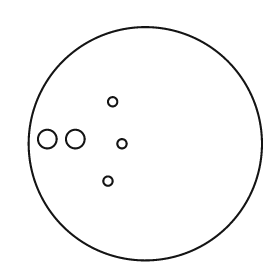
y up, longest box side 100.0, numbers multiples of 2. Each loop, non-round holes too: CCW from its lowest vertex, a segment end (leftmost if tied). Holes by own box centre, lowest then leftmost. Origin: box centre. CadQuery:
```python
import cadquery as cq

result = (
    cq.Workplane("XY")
    .moveTo(0.0, 0.0)
    .circle(50.0)
    .moveTo(-16.0, -16.0)
    .circle(2.0)
    .moveTo(-10.0, 0.0)
    .circle(2.0)
    .moveTo(-42.0, 2.0)
    .circle(4.0)
    .moveTo(-30.0, 2.0)
    .circle(4.0)
    .moveTo(-14.0, 18.0)
    .circle(2.0)
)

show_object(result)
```